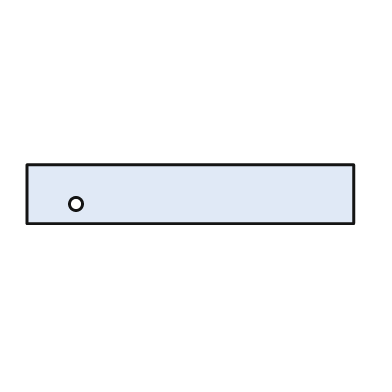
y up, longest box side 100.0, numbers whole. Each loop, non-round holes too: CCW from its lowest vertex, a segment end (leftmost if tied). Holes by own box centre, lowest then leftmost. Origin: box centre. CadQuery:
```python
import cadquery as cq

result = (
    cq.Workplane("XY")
    .moveTo(-50.0, -9.0)
    .lineTo(50.0, -9.0)
    .lineTo(50.0, 9.0)
    .lineTo(-50.0, 9.0)
    .close()
    .moveTo(-35.0, -3.0)
    .circle(2.0)
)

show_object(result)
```